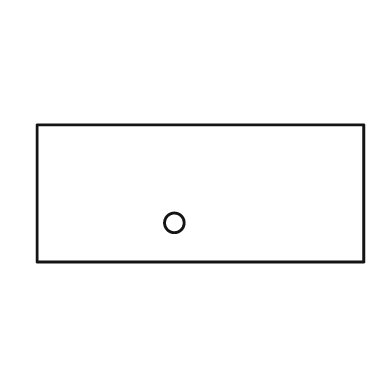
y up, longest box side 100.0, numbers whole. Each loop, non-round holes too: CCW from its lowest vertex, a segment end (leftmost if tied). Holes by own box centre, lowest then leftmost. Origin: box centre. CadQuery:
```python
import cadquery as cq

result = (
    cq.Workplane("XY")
    .moveTo(-50.0, -21.0)
    .lineTo(50.0, -21.0)
    .lineTo(50.0, 21.0)
    .lineTo(-50.0, 21.0)
    .close()
    .moveTo(-8.0, -9.0)
    .circle(3.0)
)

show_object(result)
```